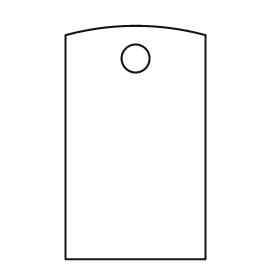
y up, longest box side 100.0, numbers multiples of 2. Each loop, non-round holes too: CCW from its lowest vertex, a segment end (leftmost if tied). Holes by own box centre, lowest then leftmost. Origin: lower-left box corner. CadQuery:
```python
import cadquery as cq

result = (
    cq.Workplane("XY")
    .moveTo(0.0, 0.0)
    .lineTo(60.0, 0.0)
    .lineTo(60.0, 96.0)
    .threePointArc((30.0, 100.0), (0.0, 96.0))
    .close()
    .moveTo(30.0, 86.0)
    .circle(6.0)
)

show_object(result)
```